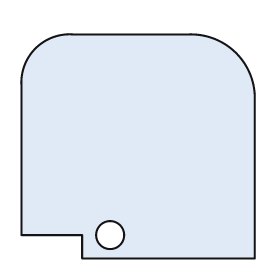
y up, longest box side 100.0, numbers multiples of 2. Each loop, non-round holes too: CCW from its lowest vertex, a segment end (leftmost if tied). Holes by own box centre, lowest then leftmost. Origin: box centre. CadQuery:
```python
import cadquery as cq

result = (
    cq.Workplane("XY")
    .moveTo(-24.0, -48.0)
    .lineTo(50.0, -48.0)
    .lineTo(50.0, 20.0)
    .threePointArc((42.0, 40.0), (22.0, 48.0))
    .lineTo(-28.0, 48.0)
    .threePointArc((-44.0, 42.0), (-50.0, 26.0))
    .lineTo(-50.0, -38.0)
    .lineTo(-24.0, -38.0)
    .close()
    .moveTo(-12.0, -38.0)
    .circle(6.0)
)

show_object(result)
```